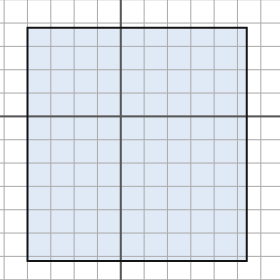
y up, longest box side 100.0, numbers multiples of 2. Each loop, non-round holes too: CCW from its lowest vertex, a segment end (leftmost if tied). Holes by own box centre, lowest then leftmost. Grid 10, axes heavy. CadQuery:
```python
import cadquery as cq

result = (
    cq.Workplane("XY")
    .moveTo(-40.0, -62.0)
    .lineTo(54.0, -62.0)
    .lineTo(54.0, 38.0)
    .lineTo(-40.0, 38.0)
    .close()
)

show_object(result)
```